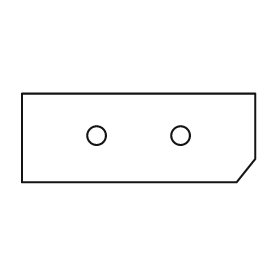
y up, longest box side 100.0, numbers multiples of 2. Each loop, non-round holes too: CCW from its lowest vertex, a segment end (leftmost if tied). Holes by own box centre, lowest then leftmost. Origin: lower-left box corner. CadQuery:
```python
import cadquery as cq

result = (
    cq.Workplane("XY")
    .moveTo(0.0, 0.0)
    .lineTo(92.0, 0.0)
    .lineTo(100.0, 10.0)
    .lineTo(100.0, 38.0)
    .lineTo(0.0, 38.0)
    .close()
    .moveTo(32.0, 20.0)
    .circle(4.0)
    .moveTo(68.0, 20.0)
    .circle(4.0)
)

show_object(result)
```